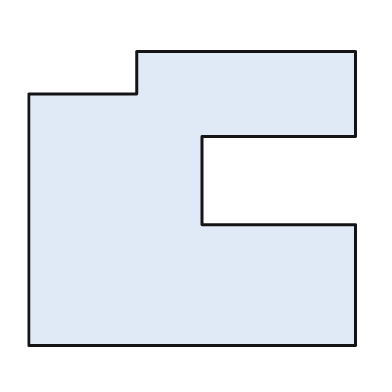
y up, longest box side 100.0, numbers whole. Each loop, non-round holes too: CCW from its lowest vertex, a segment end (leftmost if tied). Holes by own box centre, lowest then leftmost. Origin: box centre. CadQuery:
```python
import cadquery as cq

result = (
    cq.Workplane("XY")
    .moveTo(-50.0, -45.0)
    .lineTo(50.0, -45.0)
    .lineTo(50.0, -8.0)
    .lineTo(3.0, -8.0)
    .lineTo(3.0, 19.0)
    .lineTo(50.0, 19.0)
    .lineTo(50.0, 45.0)
    .lineTo(-17.0, 45.0)
    .lineTo(-17.0, 32.0)
    .lineTo(-50.0, 32.0)
    .close()
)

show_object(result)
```